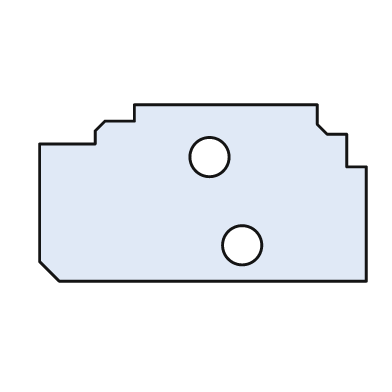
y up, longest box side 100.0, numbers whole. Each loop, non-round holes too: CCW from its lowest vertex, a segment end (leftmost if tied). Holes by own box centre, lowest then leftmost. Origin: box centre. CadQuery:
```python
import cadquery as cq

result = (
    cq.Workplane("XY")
    .moveTo(-44.0, -27.0)
    .lineTo(50.0, -27.0)
    .lineTo(50.0, 8.0)
    .lineTo(44.0, 8.0)
    .lineTo(44.0, 18.0)
    .lineTo(38.0, 18.0)
    .lineTo(35.0, 21.0)
    .lineTo(35.0, 27.0)
    .lineTo(-21.0, 27.0)
    .lineTo(-21.0, 22.0)
    .lineTo(-30.0, 22.0)
    .lineTo(-33.0, 19.0)
    .lineTo(-33.0, 15.0)
    .lineTo(-50.0, 15.0)
    .lineTo(-50.0, -21.0)
    .close()
    .moveTo(12.0, -16.0)
    .circle(6.0)
    .moveTo(2.0, 11.0)
    .circle(6.0)
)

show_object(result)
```